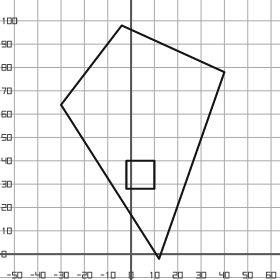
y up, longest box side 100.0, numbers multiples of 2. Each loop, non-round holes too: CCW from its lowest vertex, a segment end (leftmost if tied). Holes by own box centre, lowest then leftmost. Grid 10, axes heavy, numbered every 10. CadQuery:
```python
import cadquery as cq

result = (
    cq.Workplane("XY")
    .moveTo(12.0, -2.0)
    .lineTo(40.0, 78.0)
    .lineTo(-4.0, 98.0)
    .lineTo(-30.0, 64.0)
    .close()
    .moveTo(-2.0, 28.0)
    .lineTo(10.0, 28.0)
    .lineTo(10.0, 40.0)
    .lineTo(-2.0, 40.0)
    .close()
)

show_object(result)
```